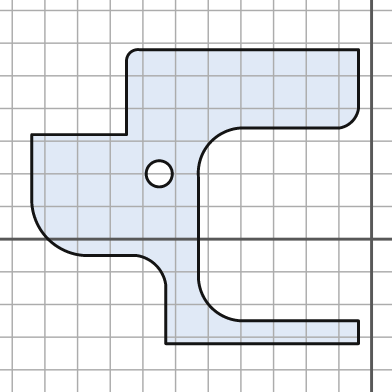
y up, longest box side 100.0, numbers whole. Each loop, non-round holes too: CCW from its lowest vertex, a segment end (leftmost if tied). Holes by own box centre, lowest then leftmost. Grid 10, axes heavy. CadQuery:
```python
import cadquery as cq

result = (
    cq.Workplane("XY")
    .moveTo(-63.0, -32.0)
    .lineTo(-4.0, -32.0)
    .lineTo(-4.0, -25.0)
    .lineTo(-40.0, -25.0)
    .threePointArc((-49.0, -21.0), (-53.0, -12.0))
    .lineTo(-53.0, 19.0)
    .threePointArc((-49.0, 30.0), (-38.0, 34.0))
    .lineTo(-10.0, 34.0)
    .threePointArc((-6.0, 36.0), (-4.0, 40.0))
    .lineTo(-4.0, 58.0)
    .lineTo(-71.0, 58.0)
    .threePointArc((-74.0, 57.0), (-75.0, 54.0))
    .lineTo(-75.0, 32.0)
    .lineTo(-104.0, 32.0)
    .lineTo(-104.0, 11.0)
    .threePointArc((-99.0, 0.0), (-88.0, -5.0))
    .lineTo(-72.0, -5.0)
    .threePointArc((-66.0, -8.0), (-63.0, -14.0))
    .close()
    .moveTo(-65.0, 20.0)
    .circle(4.0)
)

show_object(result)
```